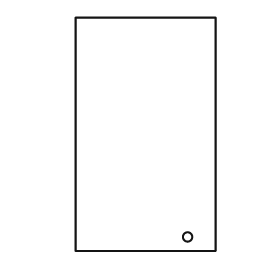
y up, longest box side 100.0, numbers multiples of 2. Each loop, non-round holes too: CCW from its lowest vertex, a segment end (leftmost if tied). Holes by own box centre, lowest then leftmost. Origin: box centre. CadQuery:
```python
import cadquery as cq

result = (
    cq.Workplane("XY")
    .moveTo(-30.0, -50.0)
    .lineTo(30.0, -50.0)
    .lineTo(30.0, 50.0)
    .lineTo(-30.0, 50.0)
    .close()
    .moveTo(18.0, -44.0)
    .circle(2.0)
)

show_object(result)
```